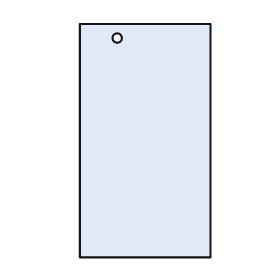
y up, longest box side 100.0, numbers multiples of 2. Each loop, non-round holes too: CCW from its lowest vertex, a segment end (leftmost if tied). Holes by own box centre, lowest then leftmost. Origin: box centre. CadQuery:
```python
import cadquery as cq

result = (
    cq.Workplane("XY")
    .moveTo(-28.0, -50.0)
    .lineTo(28.0, -50.0)
    .lineTo(28.0, 50.0)
    .lineTo(-28.0, 50.0)
    .close()
    .moveTo(-12.0, 44.0)
    .circle(2.0)
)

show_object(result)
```